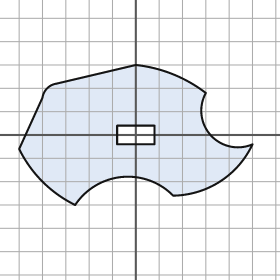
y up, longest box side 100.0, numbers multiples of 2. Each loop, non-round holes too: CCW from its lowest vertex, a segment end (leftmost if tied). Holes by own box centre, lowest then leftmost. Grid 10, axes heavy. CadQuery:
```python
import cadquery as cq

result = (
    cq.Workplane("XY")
    .moveTo(-26.0, -30.0)
    .threePointArc((-6.0, -18.0), (16.0, -26.0))
    .threePointArc((36.0, -20.0), (50.0, -4.0))
    .threePointArc((32.0, 0.0), (30.0, 18.0))
    .threePointArc((16.0, 26.0), (0.0, 30.0))
    .lineTo(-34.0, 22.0)
    .threePointArc((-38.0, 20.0), (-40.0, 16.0))
    .lineTo(-50.0, -6.0)
    .threePointArc((-40.0, -20.0), (-26.0, -30.0))
    .close()
    .moveTo(-8.0, -4.0)
    .lineTo(8.0, -4.0)
    .lineTo(8.0, 4.0)
    .lineTo(-8.0, 4.0)
    .close()
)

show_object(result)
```